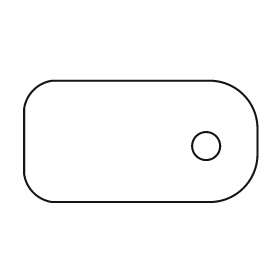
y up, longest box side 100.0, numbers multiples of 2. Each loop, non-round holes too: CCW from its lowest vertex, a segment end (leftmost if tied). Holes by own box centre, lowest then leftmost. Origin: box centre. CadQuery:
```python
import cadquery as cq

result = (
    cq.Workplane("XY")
    .moveTo(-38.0, -26.0)
    .lineTo(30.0, -26.0)
    .threePointArc((44.0, -20.0), (50.0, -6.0))
    .lineTo(50.0, 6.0)
    .threePointArc((44.0, 20.0), (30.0, 26.0))
    .lineTo(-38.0, 26.0)
    .threePointArc((-46.0, 22.0), (-50.0, 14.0))
    .lineTo(-50.0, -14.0)
    .threePointArc((-46.0, -22.0), (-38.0, -26.0))
    .close()
    .moveTo(28.0, -2.0)
    .circle(6.0)
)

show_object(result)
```